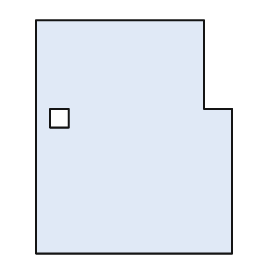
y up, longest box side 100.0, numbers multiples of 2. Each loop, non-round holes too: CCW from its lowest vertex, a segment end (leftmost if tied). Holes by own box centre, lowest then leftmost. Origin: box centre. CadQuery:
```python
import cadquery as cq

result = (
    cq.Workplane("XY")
    .moveTo(-42.0, -50.0)
    .lineTo(42.0, -50.0)
    .lineTo(42.0, 12.0)
    .lineTo(30.0, 12.0)
    .lineTo(30.0, 50.0)
    .lineTo(-42.0, 50.0)
    .close()
    .moveTo(-36.0, 4.0)
    .lineTo(-28.0, 4.0)
    .lineTo(-28.0, 12.0)
    .lineTo(-36.0, 12.0)
    .close()
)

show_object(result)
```